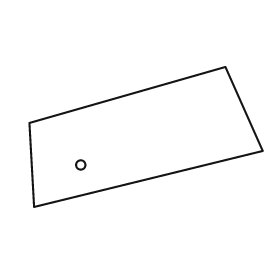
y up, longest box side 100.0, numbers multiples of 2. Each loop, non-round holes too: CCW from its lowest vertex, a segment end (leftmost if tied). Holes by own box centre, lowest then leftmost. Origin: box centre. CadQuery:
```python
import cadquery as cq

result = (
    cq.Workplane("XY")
    .moveTo(-48.0, -30.0)
    .lineTo(50.0, -6.0)
    .lineTo(34.0, 30.0)
    .lineTo(-50.0, 6.0)
    .close()
    .moveTo(-28.0, -12.0)
    .circle(2.0)
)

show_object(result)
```